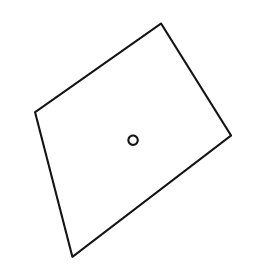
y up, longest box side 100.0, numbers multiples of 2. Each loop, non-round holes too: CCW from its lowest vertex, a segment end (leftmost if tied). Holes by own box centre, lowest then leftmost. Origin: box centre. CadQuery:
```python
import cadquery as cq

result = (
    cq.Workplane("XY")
    .moveTo(-26.0, -50.0)
    .lineTo(42.0, 2.0)
    .lineTo(12.0, 50.0)
    .lineTo(-42.0, 12.0)
    .close()
    .moveTo(0.0, 0.0)
    .circle(2.0)
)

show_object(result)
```